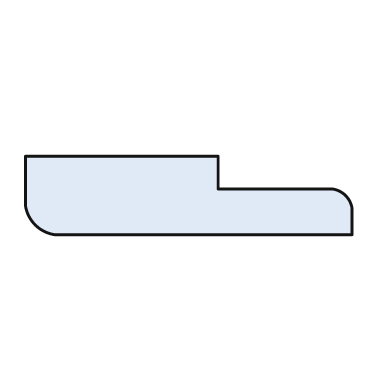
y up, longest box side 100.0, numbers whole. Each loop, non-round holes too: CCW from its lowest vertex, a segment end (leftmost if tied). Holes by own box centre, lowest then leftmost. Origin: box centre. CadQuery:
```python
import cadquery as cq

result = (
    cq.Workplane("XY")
    .moveTo(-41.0, -12.0)
    .lineTo(50.0, -12.0)
    .lineTo(50.0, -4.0)
    .threePointArc((48.0, 0.0), (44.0, 2.0))
    .lineTo(9.0, 2.0)
    .lineTo(9.0, 12.0)
    .lineTo(-50.0, 12.0)
    .lineTo(-50.0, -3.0)
    .threePointArc((-47.0, -9.0), (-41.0, -12.0))
    .close()
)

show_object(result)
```